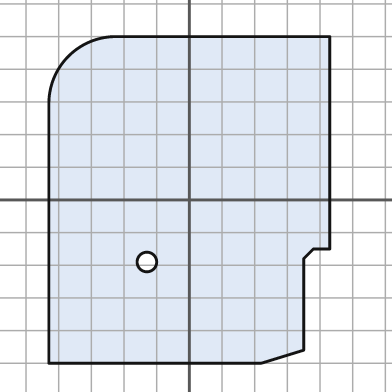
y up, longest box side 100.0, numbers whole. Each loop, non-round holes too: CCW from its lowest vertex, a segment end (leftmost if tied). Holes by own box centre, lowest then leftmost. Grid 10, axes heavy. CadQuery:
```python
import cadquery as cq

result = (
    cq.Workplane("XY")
    .moveTo(-43.0, -50.0)
    .lineTo(22.0, -50.0)
    .lineTo(35.0, -46.0)
    .lineTo(35.0, -18.0)
    .lineTo(38.0, -15.0)
    .lineTo(43.0, -15.0)
    .lineTo(43.0, 50.0)
    .lineTo(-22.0, 50.0)
    .threePointArc((-37.0, 44.0), (-43.0, 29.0))
    .close()
    .moveTo(-13.0, -19.0)
    .circle(3.0)
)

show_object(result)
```